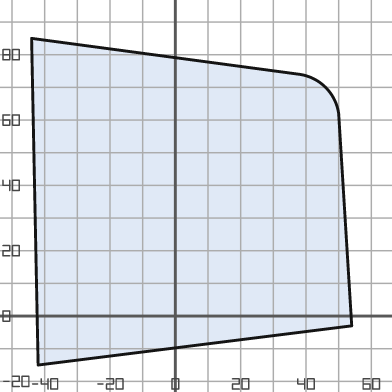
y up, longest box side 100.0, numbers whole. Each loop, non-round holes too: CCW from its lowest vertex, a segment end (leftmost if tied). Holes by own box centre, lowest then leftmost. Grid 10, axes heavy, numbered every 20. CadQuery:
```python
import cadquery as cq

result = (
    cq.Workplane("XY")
    .moveTo(-42.0, -15.0)
    .lineTo(54.0, -3.0)
    .lineTo(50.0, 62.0)
    .threePointArc((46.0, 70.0), (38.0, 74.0))
    .lineTo(-44.0, 85.0)
    .close()
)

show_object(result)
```